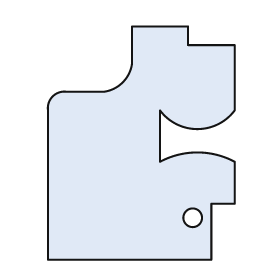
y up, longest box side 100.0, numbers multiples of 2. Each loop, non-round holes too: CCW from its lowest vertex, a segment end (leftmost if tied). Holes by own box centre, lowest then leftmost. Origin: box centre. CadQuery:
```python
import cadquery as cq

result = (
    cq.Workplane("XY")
    .moveTo(-40.0, -50.0)
    .lineTo(30.0, -50.0)
    .lineTo(30.0, -26.0)
    .lineTo(40.0, -26.0)
    .lineTo(40.0, -8.0)
    .threePointArc((24.0, -4.0), (8.0, -8.0))
    .lineTo(8.0, 14.0)
    .threePointArc((24.0, 6.0), (40.0, 14.0))
    .lineTo(40.0, 42.0)
    .lineTo(20.0, 42.0)
    .lineTo(20.0, 50.0)
    .lineTo(-4.0, 50.0)
    .lineTo(-4.0, 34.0)
    .threePointArc((-8.0, 26.0), (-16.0, 22.0))
    .lineTo(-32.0, 22.0)
    .threePointArc((-38.0, 20.0), (-40.0, 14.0))
    .close()
    .moveTo(22.0, -32.0)
    .circle(4.0)
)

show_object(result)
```